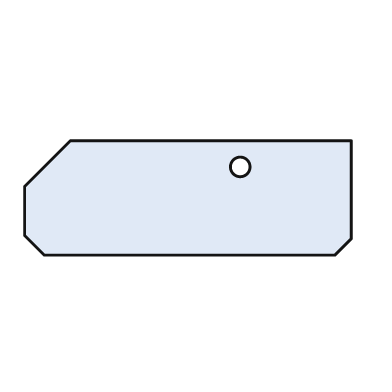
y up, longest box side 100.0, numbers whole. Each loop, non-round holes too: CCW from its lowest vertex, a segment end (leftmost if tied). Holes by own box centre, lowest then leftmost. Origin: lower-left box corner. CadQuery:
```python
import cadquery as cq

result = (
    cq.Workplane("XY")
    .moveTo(6.0, 0.0)
    .lineTo(95.0, 0.0)
    .lineTo(100.0, 5.0)
    .lineTo(100.0, 35.0)
    .lineTo(14.0, 35.0)
    .lineTo(0.0, 21.0)
    .lineTo(0.0, 6.0)
    .close()
    .moveTo(66.0, 27.0)
    .circle(3.0)
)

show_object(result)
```